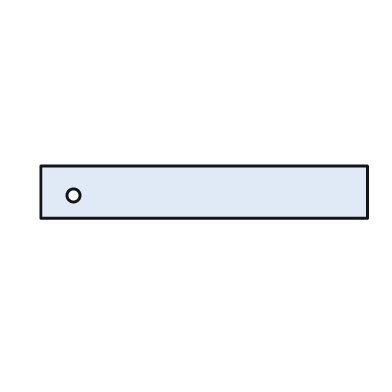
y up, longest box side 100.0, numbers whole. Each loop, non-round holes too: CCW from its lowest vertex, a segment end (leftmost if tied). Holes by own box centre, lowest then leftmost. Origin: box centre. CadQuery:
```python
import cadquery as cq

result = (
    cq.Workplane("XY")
    .moveTo(-50.0, -8.0)
    .lineTo(50.0, -8.0)
    .lineTo(50.0, 8.0)
    .lineTo(-50.0, 8.0)
    .close()
    .moveTo(-40.0, -1.0)
    .circle(2.0)
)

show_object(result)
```